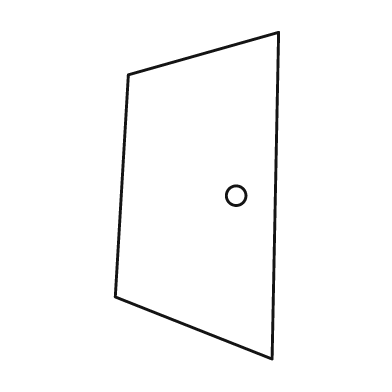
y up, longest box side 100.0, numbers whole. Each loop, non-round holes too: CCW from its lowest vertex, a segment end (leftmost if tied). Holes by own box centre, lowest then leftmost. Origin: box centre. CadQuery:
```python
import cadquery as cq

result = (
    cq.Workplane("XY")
    .moveTo(23.0, -50.0)
    .lineTo(25.0, 50.0)
    .lineTo(-21.0, 37.0)
    .lineTo(-25.0, -31.0)
    .close()
    .moveTo(12.0, 0.0)
    .circle(3.0)
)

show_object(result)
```